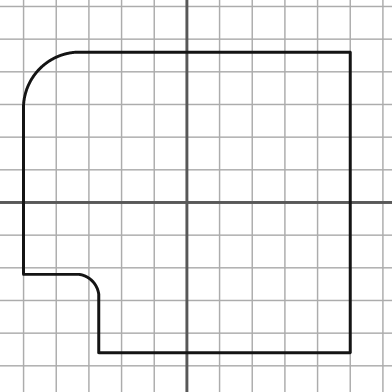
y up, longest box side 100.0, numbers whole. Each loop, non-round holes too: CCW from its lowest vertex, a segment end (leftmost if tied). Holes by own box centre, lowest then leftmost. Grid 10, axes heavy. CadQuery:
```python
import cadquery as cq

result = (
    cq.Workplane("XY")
    .moveTo(-27.0, -46.0)
    .lineTo(50.0, -46.0)
    .lineTo(50.0, 46.0)
    .lineTo(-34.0, 46.0)
    .threePointArc((-45.0, 41.0), (-50.0, 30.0))
    .lineTo(-50.0, -22.0)
    .lineTo(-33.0, -22.0)
    .threePointArc((-29.0, -24.0), (-27.0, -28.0))
    .close()
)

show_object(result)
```